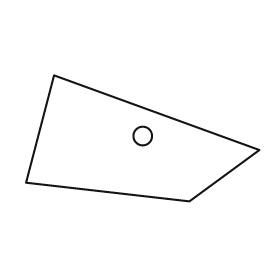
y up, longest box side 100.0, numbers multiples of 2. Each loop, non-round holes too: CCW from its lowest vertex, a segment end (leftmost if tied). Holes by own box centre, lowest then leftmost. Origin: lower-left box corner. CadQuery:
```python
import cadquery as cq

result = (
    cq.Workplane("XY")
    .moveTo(70.0, 0.0)
    .lineTo(100.0, 22.0)
    .lineTo(12.0, 54.0)
    .lineTo(0.0, 8.0)
    .close()
    .moveTo(50.0, 28.0)
    .circle(4.0)
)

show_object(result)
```